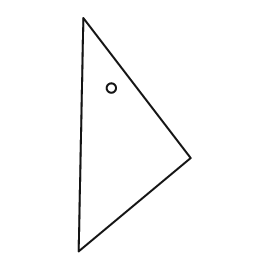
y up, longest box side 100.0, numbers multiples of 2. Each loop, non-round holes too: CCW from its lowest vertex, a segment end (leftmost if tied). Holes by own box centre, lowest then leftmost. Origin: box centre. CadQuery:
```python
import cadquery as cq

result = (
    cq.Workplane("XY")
    .moveTo(-24.0, -50.0)
    .lineTo(24.0, -10.0)
    .lineTo(-22.0, 50.0)
    .close()
    .moveTo(-10.0, 20.0)
    .circle(2.0)
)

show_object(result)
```